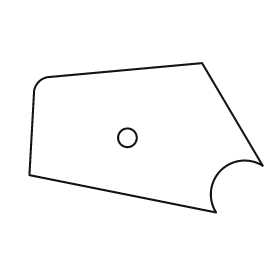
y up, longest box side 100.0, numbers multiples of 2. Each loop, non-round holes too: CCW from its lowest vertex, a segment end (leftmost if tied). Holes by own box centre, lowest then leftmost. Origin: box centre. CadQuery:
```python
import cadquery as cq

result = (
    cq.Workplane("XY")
    .moveTo(30.0, -32.0)
    .threePointArc((32.0, -14.0), (50.0, -12.0))
    .lineTo(24.0, 32.0)
    .lineTo(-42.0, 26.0)
    .threePointArc((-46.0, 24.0), (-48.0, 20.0))
    .lineTo(-50.0, -16.0)
    .close()
    .moveTo(-8.0, 0.0)
    .circle(4.0)
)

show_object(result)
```